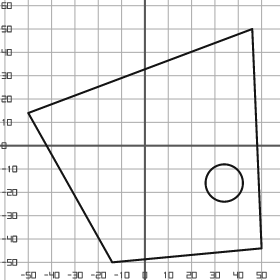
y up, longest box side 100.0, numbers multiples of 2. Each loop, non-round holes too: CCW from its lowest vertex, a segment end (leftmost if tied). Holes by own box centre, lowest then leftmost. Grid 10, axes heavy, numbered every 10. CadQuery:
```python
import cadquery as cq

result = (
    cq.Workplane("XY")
    .moveTo(-14.0, -50.0)
    .lineTo(50.0, -44.0)
    .lineTo(46.0, 50.0)
    .lineTo(-50.0, 14.0)
    .close()
    .moveTo(34.0, -16.0)
    .circle(8.0)
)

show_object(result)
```